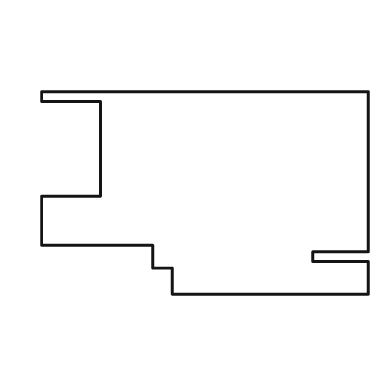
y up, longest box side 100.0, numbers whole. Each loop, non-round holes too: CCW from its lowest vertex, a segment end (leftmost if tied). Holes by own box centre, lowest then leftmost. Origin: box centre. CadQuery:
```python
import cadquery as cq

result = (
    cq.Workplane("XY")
    .moveTo(-10.0, -31.0)
    .lineTo(50.0, -31.0)
    .lineTo(50.0, -21.0)
    .lineTo(33.0, -21.0)
    .lineTo(33.0, -18.0)
    .lineTo(50.0, -18.0)
    .lineTo(50.0, 31.0)
    .lineTo(-50.0, 31.0)
    .lineTo(-50.0, 28.0)
    .lineTo(-32.0, 28.0)
    .lineTo(-32.0, -1.0)
    .lineTo(-50.0, -1.0)
    .lineTo(-50.0, -16.0)
    .lineTo(-16.0, -16.0)
    .lineTo(-16.0, -23.0)
    .lineTo(-10.0, -23.0)
    .close()
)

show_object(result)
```